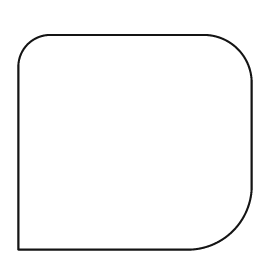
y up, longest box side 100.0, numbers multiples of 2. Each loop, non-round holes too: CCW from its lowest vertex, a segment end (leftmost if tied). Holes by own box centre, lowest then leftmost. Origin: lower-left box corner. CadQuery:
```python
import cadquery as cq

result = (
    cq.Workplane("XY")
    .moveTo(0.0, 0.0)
    .lineTo(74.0, 0.0)
    .threePointArc((92.0, 8.0), (100.0, 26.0))
    .lineTo(100.0, 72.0)
    .threePointArc((94.0, 86.0), (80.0, 92.0))
    .lineTo(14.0, 92.0)
    .threePointArc((4.0, 88.0), (0.0, 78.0))
    .close()
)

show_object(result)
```